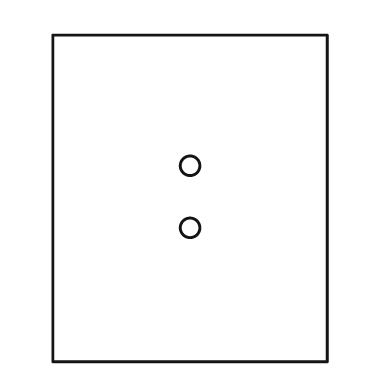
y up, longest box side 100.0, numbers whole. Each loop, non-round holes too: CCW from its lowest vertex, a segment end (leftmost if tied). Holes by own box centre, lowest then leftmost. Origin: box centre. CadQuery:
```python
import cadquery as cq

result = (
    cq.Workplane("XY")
    .moveTo(-42.0, -50.0)
    .lineTo(42.0, -50.0)
    .lineTo(42.0, 50.0)
    .lineTo(-42.0, 50.0)
    .close()
    .moveTo(0.0, -9.0)
    .circle(3.0)
    .moveTo(0.0, 10.0)
    .circle(3.0)
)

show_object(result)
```